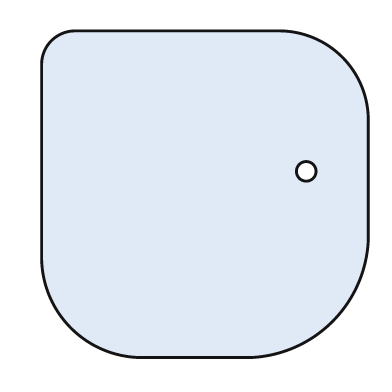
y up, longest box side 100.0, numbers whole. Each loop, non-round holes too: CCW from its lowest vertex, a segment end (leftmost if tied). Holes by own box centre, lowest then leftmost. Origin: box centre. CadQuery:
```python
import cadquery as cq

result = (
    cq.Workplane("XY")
    .moveTo(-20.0, -50.0)
    .lineTo(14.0, -50.0)
    .threePointArc((39.0, -39.0), (50.0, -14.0))
    .lineTo(50.0, 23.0)
    .threePointArc((42.0, 42.0), (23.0, 50.0))
    .lineTo(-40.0, 50.0)
    .threePointArc((-47.0, 47.0), (-50.0, 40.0))
    .lineTo(-50.0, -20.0)
    .threePointArc((-41.0, -41.0), (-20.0, -50.0))
    .close()
    .moveTo(31.0, 7.0)
    .circle(3.0)
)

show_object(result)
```